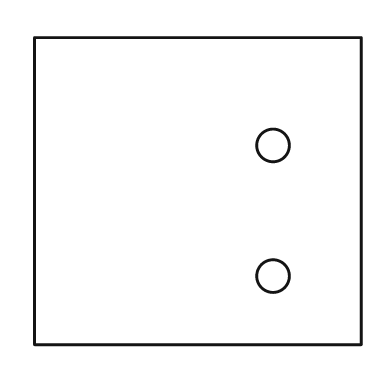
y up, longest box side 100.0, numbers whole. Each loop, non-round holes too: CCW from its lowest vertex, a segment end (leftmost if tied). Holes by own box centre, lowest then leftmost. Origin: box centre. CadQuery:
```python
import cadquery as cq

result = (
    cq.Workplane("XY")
    .moveTo(-50.0, -47.0)
    .lineTo(50.0, -47.0)
    .lineTo(50.0, 47.0)
    .lineTo(-50.0, 47.0)
    .close()
    .moveTo(23.0, -26.0)
    .circle(5.0)
    .moveTo(23.0, 14.0)
    .circle(5.0)
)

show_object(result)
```